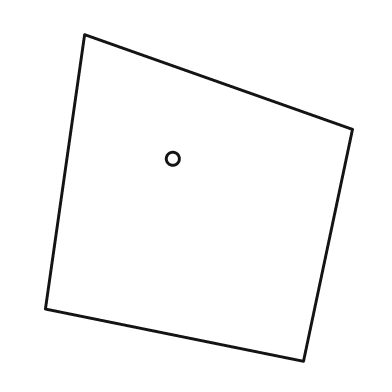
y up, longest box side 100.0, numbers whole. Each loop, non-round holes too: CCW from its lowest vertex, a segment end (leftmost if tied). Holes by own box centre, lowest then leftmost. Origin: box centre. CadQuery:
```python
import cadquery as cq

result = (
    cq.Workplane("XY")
    .moveTo(32.0, -50.0)
    .lineTo(47.0, 21.0)
    .lineTo(-35.0, 50.0)
    .lineTo(-47.0, -34.0)
    .close()
    .moveTo(-8.0, 12.0)
    .circle(2.0)
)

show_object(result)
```